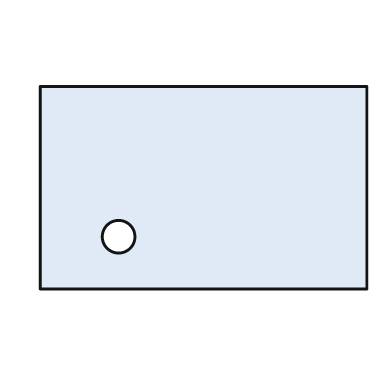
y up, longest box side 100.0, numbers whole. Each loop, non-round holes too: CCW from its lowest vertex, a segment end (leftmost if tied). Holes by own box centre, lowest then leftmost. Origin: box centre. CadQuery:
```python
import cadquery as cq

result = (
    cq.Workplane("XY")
    .moveTo(-50.0, -31.0)
    .lineTo(50.0, -31.0)
    .lineTo(50.0, 31.0)
    .lineTo(-50.0, 31.0)
    .close()
    .moveTo(-26.0, -15.0)
    .circle(5.0)
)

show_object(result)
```